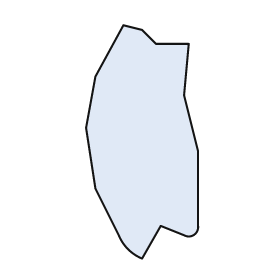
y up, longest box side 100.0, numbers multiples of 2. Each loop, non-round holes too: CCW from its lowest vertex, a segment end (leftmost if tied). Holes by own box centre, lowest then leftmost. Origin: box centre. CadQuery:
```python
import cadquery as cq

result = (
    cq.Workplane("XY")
    .moveTo(0.0, -50.0)
    .lineTo(8.0, -36.0)
    .lineTo(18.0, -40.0)
    .threePointArc((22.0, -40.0), (24.0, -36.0))
    .lineTo(24.0, -4.0)
    .lineTo(18.0, 20.0)
    .lineTo(20.0, 42.0)
    .lineTo(6.0, 42.0)
    .lineTo(0.0, 48.0)
    .lineTo(-8.0, 50.0)
    .lineTo(-20.0, 28.0)
    .lineTo(-24.0, 6.0)
    .lineTo(-20.0, -20.0)
    .lineTo(-10.0, -40.0)
    .threePointArc((-6.0, -46.0), (0.0, -50.0))
    .close()
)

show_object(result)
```